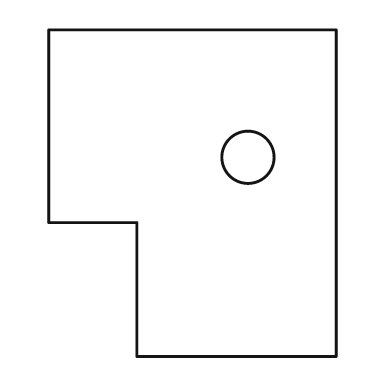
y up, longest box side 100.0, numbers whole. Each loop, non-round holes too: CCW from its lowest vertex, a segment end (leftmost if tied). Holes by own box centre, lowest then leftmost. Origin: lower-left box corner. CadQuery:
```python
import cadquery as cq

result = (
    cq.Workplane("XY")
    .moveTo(27.0, 0.0)
    .lineTo(88.0, 0.0)
    .lineTo(88.0, 100.0)
    .lineTo(0.0, 100.0)
    .lineTo(0.0, 41.0)
    .lineTo(27.0, 41.0)
    .close()
    .moveTo(61.0, 61.0)
    .circle(8.0)
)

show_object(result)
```